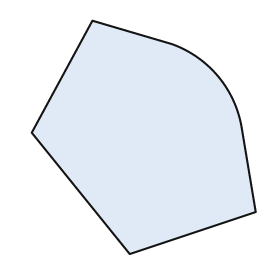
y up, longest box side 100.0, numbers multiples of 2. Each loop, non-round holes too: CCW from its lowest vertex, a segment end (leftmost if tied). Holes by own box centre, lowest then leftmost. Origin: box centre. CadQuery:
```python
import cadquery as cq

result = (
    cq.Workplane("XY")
    .moveTo(-6.0, -50.0)
    .lineTo(48.0, -32.0)
    .lineTo(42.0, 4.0)
    .threePointArc((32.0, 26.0), (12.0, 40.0))
    .lineTo(-22.0, 50.0)
    .lineTo(-48.0, 2.0)
    .close()
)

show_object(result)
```